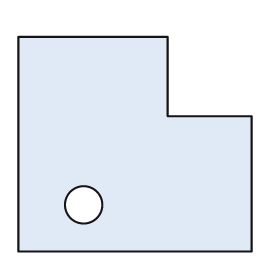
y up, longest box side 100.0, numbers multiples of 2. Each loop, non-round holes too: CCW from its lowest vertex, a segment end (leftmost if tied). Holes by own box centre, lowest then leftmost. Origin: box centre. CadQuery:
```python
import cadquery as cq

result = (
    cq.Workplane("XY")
    .moveTo(-50.0, -46.0)
    .lineTo(50.0, -46.0)
    .lineTo(50.0, 12.0)
    .lineTo(14.0, 12.0)
    .lineTo(14.0, 46.0)
    .lineTo(-50.0, 46.0)
    .close()
    .moveTo(-22.0, -26.0)
    .circle(8.0)
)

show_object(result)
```